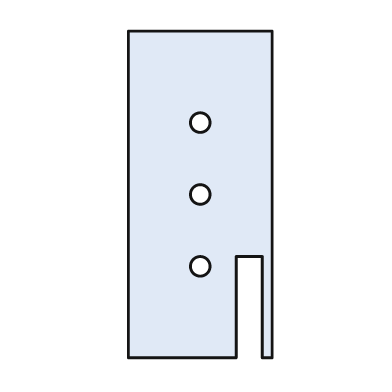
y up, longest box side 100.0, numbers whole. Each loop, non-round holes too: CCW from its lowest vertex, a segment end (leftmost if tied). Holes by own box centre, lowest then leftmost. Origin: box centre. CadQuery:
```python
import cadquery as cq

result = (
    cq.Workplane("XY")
    .moveTo(-22.0, -50.0)
    .lineTo(11.0, -50.0)
    .lineTo(11.0, -19.0)
    .lineTo(19.0, -19.0)
    .lineTo(19.0, -50.0)
    .lineTo(22.0, -50.0)
    .lineTo(22.0, 50.0)
    .lineTo(-22.0, 50.0)
    .close()
    .moveTo(0.0, -22.0)
    .circle(3.0)
    .moveTo(0.0, 0.0)
    .circle(3.0)
    .moveTo(0.0, 22.0)
    .circle(3.0)
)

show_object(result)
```